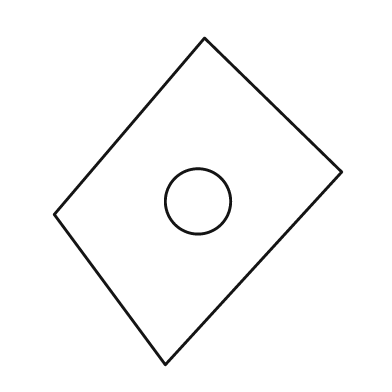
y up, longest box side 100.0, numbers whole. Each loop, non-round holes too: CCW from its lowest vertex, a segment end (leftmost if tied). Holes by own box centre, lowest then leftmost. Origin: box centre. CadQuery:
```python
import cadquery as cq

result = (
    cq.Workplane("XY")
    .moveTo(-10.0, -50.0)
    .lineTo(44.0, 9.0)
    .lineTo(2.0, 50.0)
    .lineTo(-44.0, -4.0)
    .close()
    .moveTo(0.0, 0.0)
    .circle(10.0)
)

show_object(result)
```